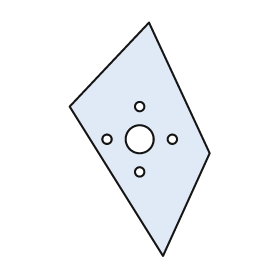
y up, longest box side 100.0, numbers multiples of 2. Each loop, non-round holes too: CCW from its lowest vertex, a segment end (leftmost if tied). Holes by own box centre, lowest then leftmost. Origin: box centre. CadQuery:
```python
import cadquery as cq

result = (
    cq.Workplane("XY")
    .moveTo(10.0, -50.0)
    .lineTo(30.0, -6.0)
    .lineTo(4.0, 50.0)
    .lineTo(-30.0, 14.0)
    .close()
    .moveTo(0.0, -14.0)
    .circle(2.0)
    .moveTo(-14.0, 0.0)
    .circle(2.0)
    .moveTo(0.0, 0.0)
    .circle(6.0)
    .moveTo(14.0, 0.0)
    .circle(2.0)
    .moveTo(0.0, 14.0)
    .circle(2.0)
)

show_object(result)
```